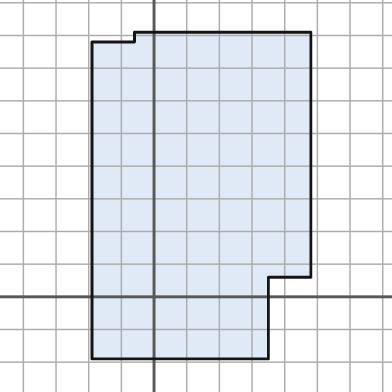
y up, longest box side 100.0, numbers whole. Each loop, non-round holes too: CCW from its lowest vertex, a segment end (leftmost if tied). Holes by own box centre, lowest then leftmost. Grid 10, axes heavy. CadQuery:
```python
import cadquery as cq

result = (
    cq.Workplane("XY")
    .moveTo(-19.0, -19.0)
    .lineTo(35.0, -19.0)
    .lineTo(35.0, 6.0)
    .lineTo(48.0, 6.0)
    .lineTo(48.0, 81.0)
    .lineTo(-6.0, 81.0)
    .lineTo(-6.0, 78.0)
    .lineTo(-19.0, 78.0)
    .close()
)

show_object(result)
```